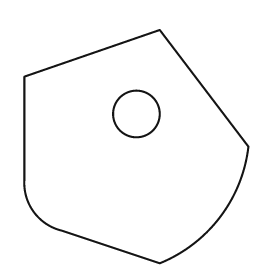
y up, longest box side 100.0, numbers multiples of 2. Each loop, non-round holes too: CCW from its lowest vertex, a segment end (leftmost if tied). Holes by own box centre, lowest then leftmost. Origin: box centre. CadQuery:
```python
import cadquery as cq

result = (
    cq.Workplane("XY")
    .moveTo(10.0, -50.0)
    .threePointArc((36.0, -30.0), (48.0, 0.0))
    .lineTo(10.0, 50.0)
    .lineTo(-48.0, 30.0)
    .lineTo(-48.0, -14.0)
    .threePointArc((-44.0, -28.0), (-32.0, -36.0))
    .close()
    .moveTo(0.0, 14.0)
    .circle(10.0)
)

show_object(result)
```